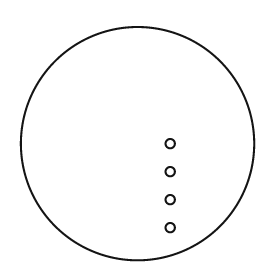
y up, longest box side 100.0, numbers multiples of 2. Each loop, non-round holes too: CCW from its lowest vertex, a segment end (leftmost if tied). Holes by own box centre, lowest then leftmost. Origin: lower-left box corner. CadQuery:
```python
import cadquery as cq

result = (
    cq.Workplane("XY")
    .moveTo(50.0, 50.0)
    .circle(50.0)
    .moveTo(64.0, 14.0)
    .circle(2.0)
    .moveTo(64.0, 26.0)
    .circle(2.0)
    .moveTo(64.0, 38.0)
    .circle(2.0)
    .moveTo(64.0, 50.0)
    .circle(2.0)
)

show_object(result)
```